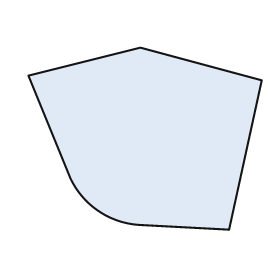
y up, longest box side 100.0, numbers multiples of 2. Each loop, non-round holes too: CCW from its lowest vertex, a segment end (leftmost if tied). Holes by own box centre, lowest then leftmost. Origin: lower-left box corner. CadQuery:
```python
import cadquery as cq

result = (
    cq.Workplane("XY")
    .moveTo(86.0, 0.0)
    .lineTo(100.0, 64.0)
    .lineTo(48.0, 78.0)
    .lineTo(0.0, 66.0)
    .lineTo(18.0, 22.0)
    .threePointArc((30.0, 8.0), (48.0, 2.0))
    .close()
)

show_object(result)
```